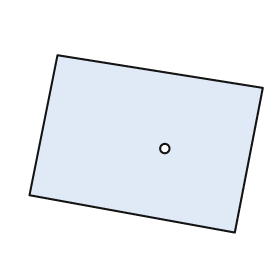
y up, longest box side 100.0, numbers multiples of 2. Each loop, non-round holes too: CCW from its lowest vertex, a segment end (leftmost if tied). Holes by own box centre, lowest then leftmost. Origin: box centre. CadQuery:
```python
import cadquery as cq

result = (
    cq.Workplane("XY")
    .moveTo(38.0, -38.0)
    .lineTo(50.0, 24.0)
    .lineTo(-38.0, 38.0)
    .lineTo(-50.0, -22.0)
    .close()
    .moveTo(8.0, -2.0)
    .circle(2.0)
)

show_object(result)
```